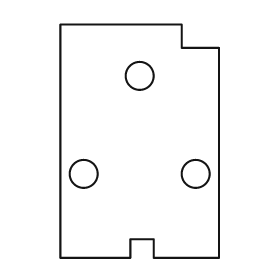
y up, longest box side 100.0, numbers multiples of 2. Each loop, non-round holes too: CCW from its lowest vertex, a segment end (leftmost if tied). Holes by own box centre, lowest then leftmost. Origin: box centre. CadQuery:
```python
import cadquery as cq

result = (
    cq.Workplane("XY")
    .moveTo(-34.0, -50.0)
    .lineTo(-4.0, -50.0)
    .lineTo(-4.0, -42.0)
    .lineTo(6.0, -42.0)
    .lineTo(6.0, -50.0)
    .lineTo(34.0, -50.0)
    .lineTo(34.0, 40.0)
    .lineTo(18.0, 40.0)
    .lineTo(18.0, 50.0)
    .lineTo(-34.0, 50.0)
    .close()
    .moveTo(-24.0, -14.0)
    .circle(6.0)
    .moveTo(24.0, -14.0)
    .circle(6.0)
    .moveTo(0.0, 28.0)
    .circle(6.0)
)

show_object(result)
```